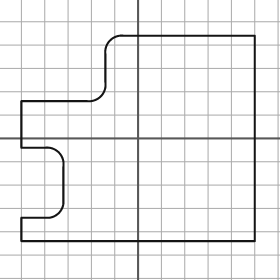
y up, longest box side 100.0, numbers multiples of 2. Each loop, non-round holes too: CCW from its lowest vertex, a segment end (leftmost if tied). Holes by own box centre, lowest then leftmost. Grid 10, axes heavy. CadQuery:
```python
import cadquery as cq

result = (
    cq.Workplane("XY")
    .moveTo(-50.0, -44.0)
    .lineTo(50.0, -44.0)
    .lineTo(50.0, 44.0)
    .lineTo(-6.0, 44.0)
    .threePointArc((-12.0, 42.0), (-14.0, 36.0))
    .lineTo(-14.0, 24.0)
    .threePointArc((-16.0, 18.0), (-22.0, 16.0))
    .lineTo(-50.0, 16.0)
    .lineTo(-50.0, -4.0)
    .lineTo(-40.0, -4.0)
    .threePointArc((-34.0, -6.0), (-32.0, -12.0))
    .lineTo(-32.0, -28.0)
    .threePointArc((-34.0, -32.0), (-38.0, -34.0))
    .lineTo(-50.0, -34.0)
    .close()
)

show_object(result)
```